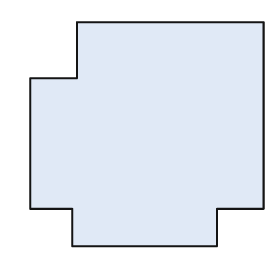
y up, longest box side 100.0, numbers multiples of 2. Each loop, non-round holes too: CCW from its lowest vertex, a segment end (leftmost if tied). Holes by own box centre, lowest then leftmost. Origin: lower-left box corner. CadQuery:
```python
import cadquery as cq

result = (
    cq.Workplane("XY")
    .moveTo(18.0, 0.0)
    .lineTo(80.0, 0.0)
    .lineTo(80.0, 16.0)
    .lineTo(100.0, 16.0)
    .lineTo(100.0, 96.0)
    .lineTo(20.0, 96.0)
    .lineTo(20.0, 72.0)
    .lineTo(0.0, 72.0)
    .lineTo(0.0, 16.0)
    .lineTo(18.0, 16.0)
    .close()
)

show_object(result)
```